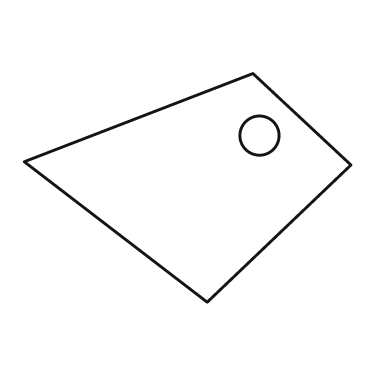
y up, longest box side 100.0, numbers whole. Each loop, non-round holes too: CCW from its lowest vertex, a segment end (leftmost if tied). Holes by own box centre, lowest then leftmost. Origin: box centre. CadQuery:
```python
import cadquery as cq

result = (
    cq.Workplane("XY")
    .moveTo(6.0, -35.0)
    .lineTo(50.0, 7.0)
    .lineTo(20.0, 35.0)
    .lineTo(-50.0, 8.0)
    .close()
    .moveTo(22.0, 16.0)
    .circle(6.0)
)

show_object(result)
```